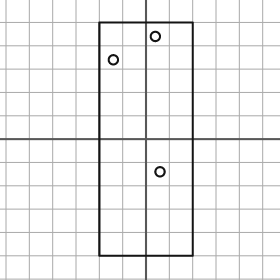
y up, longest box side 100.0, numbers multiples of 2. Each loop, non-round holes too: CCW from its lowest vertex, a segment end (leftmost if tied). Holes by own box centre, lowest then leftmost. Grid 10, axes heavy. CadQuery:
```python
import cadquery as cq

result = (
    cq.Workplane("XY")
    .moveTo(-20.0, -50.0)
    .lineTo(20.0, -50.0)
    .lineTo(20.0, 50.0)
    .lineTo(-20.0, 50.0)
    .close()
    .moveTo(6.0, -14.0)
    .circle(2.0)
    .moveTo(-14.0, 34.0)
    .circle(2.0)
    .moveTo(4.0, 44.0)
    .circle(2.0)
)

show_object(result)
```